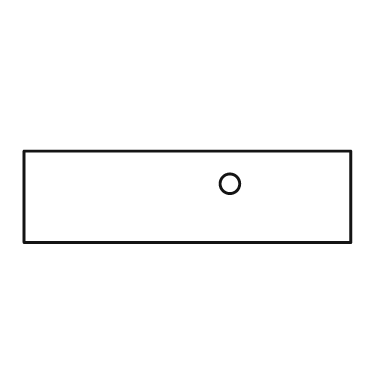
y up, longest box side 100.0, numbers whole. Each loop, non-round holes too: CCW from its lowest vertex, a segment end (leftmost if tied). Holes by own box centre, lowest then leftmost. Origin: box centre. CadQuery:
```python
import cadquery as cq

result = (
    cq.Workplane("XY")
    .moveTo(-50.0, -14.0)
    .lineTo(50.0, -14.0)
    .lineTo(50.0, 14.0)
    .lineTo(-50.0, 14.0)
    .close()
    .moveTo(13.0, 4.0)
    .circle(3.0)
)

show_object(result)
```